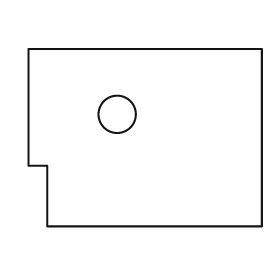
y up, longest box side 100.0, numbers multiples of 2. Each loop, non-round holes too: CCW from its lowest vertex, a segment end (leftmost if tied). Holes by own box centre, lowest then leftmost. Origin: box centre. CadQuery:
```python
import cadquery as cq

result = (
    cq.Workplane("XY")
    .moveTo(-42.0, -38.0)
    .lineTo(50.0, -38.0)
    .lineTo(50.0, 38.0)
    .lineTo(-50.0, 38.0)
    .lineTo(-50.0, -12.0)
    .lineTo(-42.0, -12.0)
    .close()
    .moveTo(-12.0, 10.0)
    .circle(8.0)
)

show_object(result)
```